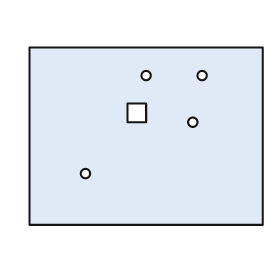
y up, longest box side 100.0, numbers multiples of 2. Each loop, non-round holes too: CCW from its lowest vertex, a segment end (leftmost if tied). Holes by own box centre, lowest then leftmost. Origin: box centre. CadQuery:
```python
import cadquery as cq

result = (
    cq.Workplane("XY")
    .moveTo(-50.0, -38.0)
    .lineTo(50.0, -38.0)
    .lineTo(50.0, 38.0)
    .lineTo(-50.0, 38.0)
    .close()
    .moveTo(-26.0, -16.0)
    .circle(2.0)
    .moveTo(20.0, 6.0)
    .circle(2.0)
    .moveTo(-8.0, 6.0)
    .lineTo(0.0, 6.0)
    .lineTo(0.0, 14.0)
    .lineTo(-8.0, 14.0)
    .close()
    .moveTo(0.0, 26.0)
    .circle(2.0)
    .moveTo(24.0, 26.0)
    .circle(2.0)
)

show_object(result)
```